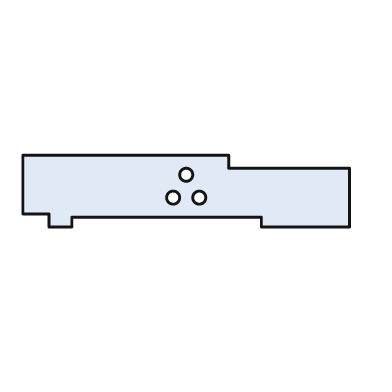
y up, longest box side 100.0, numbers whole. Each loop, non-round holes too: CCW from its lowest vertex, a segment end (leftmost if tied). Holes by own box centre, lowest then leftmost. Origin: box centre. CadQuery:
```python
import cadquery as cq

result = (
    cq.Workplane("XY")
    .moveTo(-42.0, -11.0)
    .lineTo(-35.0, -11.0)
    .lineTo(-35.0, -8.0)
    .lineTo(23.0, -8.0)
    .lineTo(23.0, -11.0)
    .lineTo(50.0, -11.0)
    .lineTo(50.0, 7.0)
    .lineTo(13.0, 7.0)
    .lineTo(13.0, 11.0)
    .lineTo(-50.0, 11.0)
    .lineTo(-50.0, -7.0)
    .lineTo(-42.0, -7.0)
    .close()
    .moveTo(-4.0, -2.0)
    .circle(2.0)
    .moveTo(4.0, -2.0)
    .circle(2.0)
    .moveTo(0.0, 5.0)
    .circle(2.0)
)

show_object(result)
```